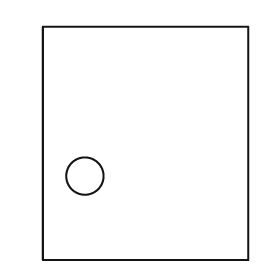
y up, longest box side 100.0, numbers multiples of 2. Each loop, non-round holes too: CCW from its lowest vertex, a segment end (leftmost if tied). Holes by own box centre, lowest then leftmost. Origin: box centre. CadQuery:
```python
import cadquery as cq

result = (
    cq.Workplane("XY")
    .moveTo(-44.0, -50.0)
    .lineTo(44.0, -50.0)
    .lineTo(44.0, 50.0)
    .lineTo(-44.0, 50.0)
    .close()
    .moveTo(-26.0, -14.0)
    .circle(8.0)
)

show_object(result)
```